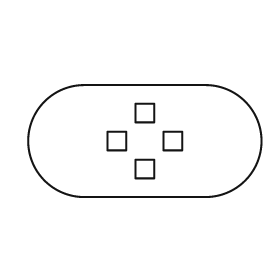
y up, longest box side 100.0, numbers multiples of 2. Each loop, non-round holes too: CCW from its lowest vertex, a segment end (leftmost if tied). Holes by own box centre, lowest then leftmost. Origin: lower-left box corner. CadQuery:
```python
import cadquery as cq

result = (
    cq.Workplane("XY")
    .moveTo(24.0, 0.0)
    .lineTo(76.0, 0.0)
    .threePointArc((100.0, 24.0), (76.0, 48.0))
    .lineTo(24.0, 48.0)
    .threePointArc((0.0, 24.0), (24.0, 0.0))
    .close()
    .moveTo(46.0, 8.0)
    .lineTo(54.0, 8.0)
    .lineTo(54.0, 16.0)
    .lineTo(46.0, 16.0)
    .close()
    .moveTo(34.0, 20.0)
    .lineTo(42.0, 20.0)
    .lineTo(42.0, 28.0)
    .lineTo(34.0, 28.0)
    .close()
    .moveTo(58.0, 20.0)
    .lineTo(66.0, 20.0)
    .lineTo(66.0, 28.0)
    .lineTo(58.0, 28.0)
    .close()
    .moveTo(46.0, 32.0)
    .lineTo(54.0, 32.0)
    .lineTo(54.0, 40.0)
    .lineTo(46.0, 40.0)
    .close()
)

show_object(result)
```